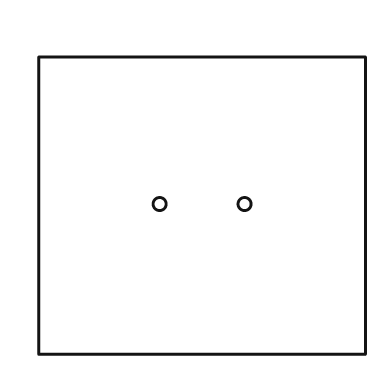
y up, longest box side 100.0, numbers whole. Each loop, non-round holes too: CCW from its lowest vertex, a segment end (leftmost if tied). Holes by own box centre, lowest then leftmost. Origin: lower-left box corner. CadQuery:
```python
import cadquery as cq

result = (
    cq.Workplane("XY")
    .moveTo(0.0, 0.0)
    .lineTo(100.0, 0.0)
    .lineTo(100.0, 91.0)
    .lineTo(0.0, 91.0)
    .close()
    .moveTo(37.0, 46.0)
    .circle(2.0)
    .moveTo(63.0, 46.0)
    .circle(2.0)
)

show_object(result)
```